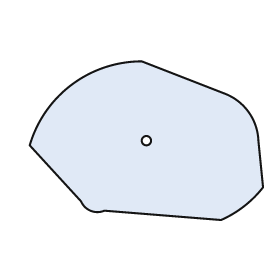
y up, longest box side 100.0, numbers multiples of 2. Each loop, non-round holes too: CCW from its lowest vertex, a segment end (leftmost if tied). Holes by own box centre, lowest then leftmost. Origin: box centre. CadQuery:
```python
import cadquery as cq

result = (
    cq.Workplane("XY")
    .moveTo(32.0, -34.0)
    .threePointArc((42.0, -28.0), (50.0, -20.0))
    .lineTo(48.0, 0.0)
    .threePointArc((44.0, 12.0), (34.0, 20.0))
    .lineTo(-2.0, 34.0)
    .threePointArc((-32.0, 24.0), (-50.0, -2.0))
    .lineTo(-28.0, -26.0)
    .threePointArc((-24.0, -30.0), (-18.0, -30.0))
    .close()
    .moveTo(0.0, 0.0)
    .circle(2.0)
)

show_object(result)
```